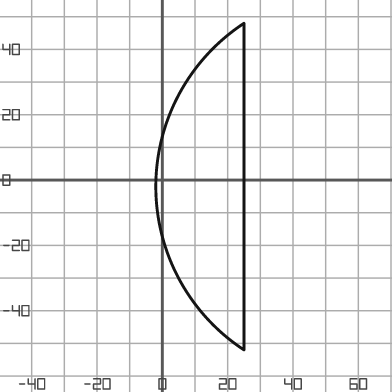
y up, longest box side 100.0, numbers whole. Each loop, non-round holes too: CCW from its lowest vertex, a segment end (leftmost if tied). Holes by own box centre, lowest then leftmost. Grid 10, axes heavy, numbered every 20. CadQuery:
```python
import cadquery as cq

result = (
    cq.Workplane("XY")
    .moveTo(25.0, -52.0)
    .lineTo(25.0, 48.0)
    .threePointArc((-2.0, -2.0), (25.0, -52.0))
    .close()
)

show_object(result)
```